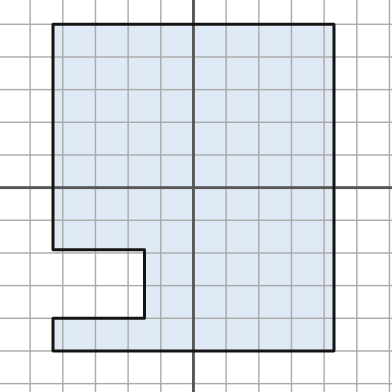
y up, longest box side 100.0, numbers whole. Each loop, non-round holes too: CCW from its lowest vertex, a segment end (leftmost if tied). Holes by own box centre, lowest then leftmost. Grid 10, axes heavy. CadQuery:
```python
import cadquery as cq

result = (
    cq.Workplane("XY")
    .moveTo(-43.0, -50.0)
    .lineTo(43.0, -50.0)
    .lineTo(43.0, 50.0)
    .lineTo(-43.0, 50.0)
    .lineTo(-43.0, -19.0)
    .lineTo(-15.0, -19.0)
    .lineTo(-15.0, -40.0)
    .lineTo(-43.0, -40.0)
    .close()
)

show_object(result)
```